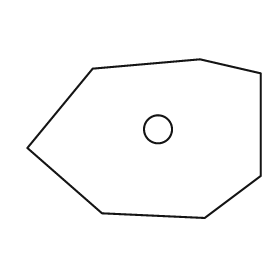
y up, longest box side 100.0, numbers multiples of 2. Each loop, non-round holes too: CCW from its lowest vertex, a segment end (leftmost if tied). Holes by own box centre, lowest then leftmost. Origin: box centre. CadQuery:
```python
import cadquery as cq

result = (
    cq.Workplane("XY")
    .moveTo(26.0, -34.0)
    .lineTo(50.0, -16.0)
    .lineTo(50.0, 28.0)
    .lineTo(24.0, 34.0)
    .lineTo(-22.0, 30.0)
    .lineTo(-50.0, -4.0)
    .lineTo(-18.0, -32.0)
    .close()
    .moveTo(6.0, 4.0)
    .circle(6.0)
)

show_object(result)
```